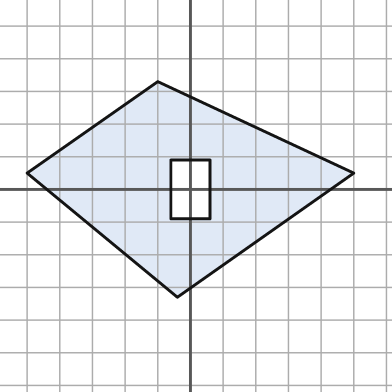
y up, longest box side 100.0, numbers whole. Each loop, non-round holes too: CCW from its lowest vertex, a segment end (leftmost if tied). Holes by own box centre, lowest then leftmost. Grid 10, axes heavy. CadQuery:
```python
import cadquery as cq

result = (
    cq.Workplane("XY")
    .moveTo(-4.0, -33.0)
    .lineTo(50.0, 5.0)
    .lineTo(-10.0, 33.0)
    .lineTo(-50.0, 5.0)
    .close()
    .moveTo(-6.0, -9.0)
    .lineTo(6.0, -9.0)
    .lineTo(6.0, 9.0)
    .lineTo(-6.0, 9.0)
    .close()
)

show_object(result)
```